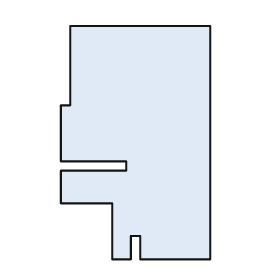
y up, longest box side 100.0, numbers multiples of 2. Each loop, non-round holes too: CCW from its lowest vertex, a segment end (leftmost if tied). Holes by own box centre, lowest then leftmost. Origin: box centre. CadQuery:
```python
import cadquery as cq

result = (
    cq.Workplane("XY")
    .moveTo(-10.0, -50.0)
    .lineTo(-2.0, -50.0)
    .lineTo(-2.0, -40.0)
    .lineTo(2.0, -40.0)
    .lineTo(2.0, -50.0)
    .lineTo(32.0, -50.0)
    .lineTo(32.0, 50.0)
    .lineTo(-28.0, 50.0)
    .lineTo(-28.0, 16.0)
    .lineTo(-32.0, 16.0)
    .lineTo(-32.0, -8.0)
    .lineTo(-4.0, -8.0)
    .lineTo(-4.0, -12.0)
    .lineTo(-32.0, -12.0)
    .lineTo(-32.0, -26.0)
    .lineTo(-10.0, -26.0)
    .close()
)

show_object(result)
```